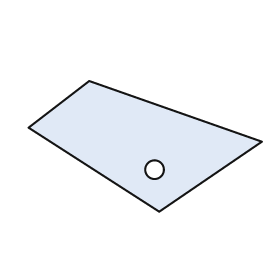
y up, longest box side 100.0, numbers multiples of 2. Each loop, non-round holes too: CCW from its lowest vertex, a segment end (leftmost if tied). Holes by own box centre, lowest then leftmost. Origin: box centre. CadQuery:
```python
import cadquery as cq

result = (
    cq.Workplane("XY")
    .moveTo(6.0, -28.0)
    .lineTo(50.0, 2.0)
    .lineTo(-24.0, 28.0)
    .lineTo(-50.0, 8.0)
    .close()
    .moveTo(4.0, -10.0)
    .circle(4.0)
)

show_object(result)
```